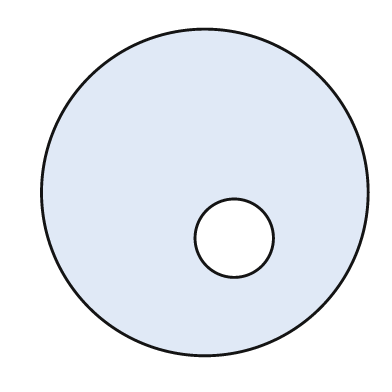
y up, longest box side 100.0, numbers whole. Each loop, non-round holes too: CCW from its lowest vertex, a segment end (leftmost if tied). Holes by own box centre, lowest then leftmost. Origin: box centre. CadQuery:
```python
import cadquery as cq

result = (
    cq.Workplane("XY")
    .moveTo(0.0, 0.0)
    .circle(50.0)
    .moveTo(9.0, -14.0)
    .circle(12.0)
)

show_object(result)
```